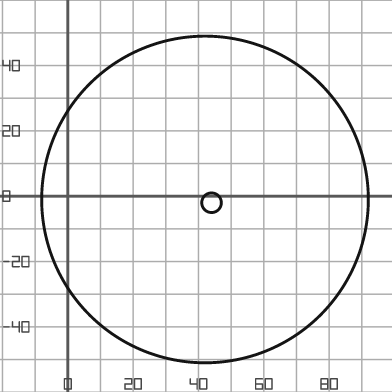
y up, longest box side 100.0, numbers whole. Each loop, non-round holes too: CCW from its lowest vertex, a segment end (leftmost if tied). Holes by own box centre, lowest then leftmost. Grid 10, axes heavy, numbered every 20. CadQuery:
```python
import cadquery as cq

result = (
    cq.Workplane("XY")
    .moveTo(42.0, -1.0)
    .circle(50.0)
    .moveTo(44.0, -2.0)
    .circle(3.0)
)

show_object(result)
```